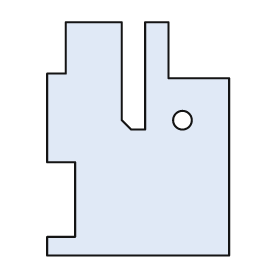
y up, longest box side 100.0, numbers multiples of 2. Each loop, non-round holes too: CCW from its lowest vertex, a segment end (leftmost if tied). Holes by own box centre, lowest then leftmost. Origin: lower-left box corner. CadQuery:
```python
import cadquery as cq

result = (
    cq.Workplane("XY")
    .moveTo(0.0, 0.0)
    .lineTo(78.0, 0.0)
    .lineTo(78.0, 76.0)
    .lineTo(52.0, 76.0)
    .lineTo(52.0, 100.0)
    .lineTo(42.0, 100.0)
    .lineTo(42.0, 54.0)
    .lineTo(36.0, 54.0)
    .lineTo(32.0, 58.0)
    .lineTo(32.0, 100.0)
    .lineTo(8.0, 100.0)
    .lineTo(8.0, 78.0)
    .lineTo(0.0, 78.0)
    .lineTo(0.0, 40.0)
    .lineTo(12.0, 40.0)
    .lineTo(12.0, 8.0)
    .lineTo(0.0, 8.0)
    .close()
    .moveTo(58.0, 58.0)
    .circle(4.0)
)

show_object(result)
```